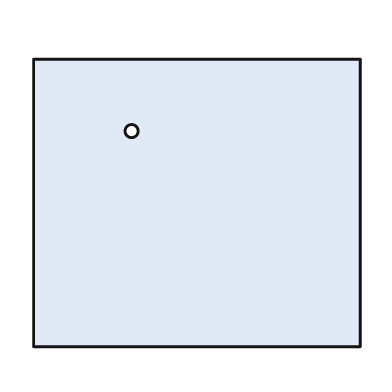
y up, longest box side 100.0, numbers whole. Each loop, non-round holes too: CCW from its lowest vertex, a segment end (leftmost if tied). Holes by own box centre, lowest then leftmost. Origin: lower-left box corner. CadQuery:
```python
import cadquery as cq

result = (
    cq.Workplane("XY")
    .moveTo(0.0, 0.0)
    .lineTo(100.0, 0.0)
    .lineTo(100.0, 88.0)
    .lineTo(0.0, 88.0)
    .close()
    .moveTo(30.0, 66.0)
    .circle(2.0)
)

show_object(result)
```